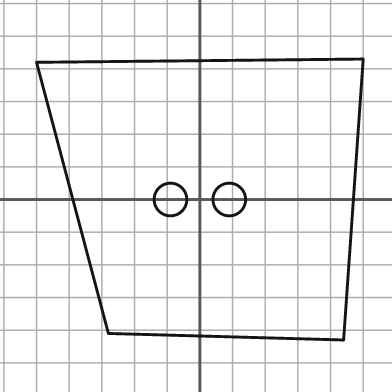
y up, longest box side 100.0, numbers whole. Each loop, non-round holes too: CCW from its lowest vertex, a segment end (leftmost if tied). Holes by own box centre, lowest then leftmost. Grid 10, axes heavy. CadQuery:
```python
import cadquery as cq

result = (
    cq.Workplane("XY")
    .moveTo(44.0, -43.0)
    .lineTo(50.0, 43.0)
    .lineTo(-50.0, 42.0)
    .lineTo(-28.0, -41.0)
    .close()
    .moveTo(-9.0, 0.0)
    .circle(5.0)
    .moveTo(9.0, 0.0)
    .circle(5.0)
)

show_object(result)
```